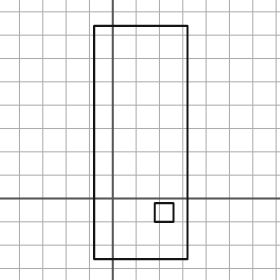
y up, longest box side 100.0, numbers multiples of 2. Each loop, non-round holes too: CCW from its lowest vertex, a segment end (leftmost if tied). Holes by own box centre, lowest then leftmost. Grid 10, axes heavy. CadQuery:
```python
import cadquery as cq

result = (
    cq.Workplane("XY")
    .moveTo(-8.0, -26.0)
    .lineTo(32.0, -26.0)
    .lineTo(32.0, 74.0)
    .lineTo(-8.0, 74.0)
    .close()
    .moveTo(18.0, -10.0)
    .lineTo(26.0, -10.0)
    .lineTo(26.0, -2.0)
    .lineTo(18.0, -2.0)
    .close()
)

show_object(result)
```